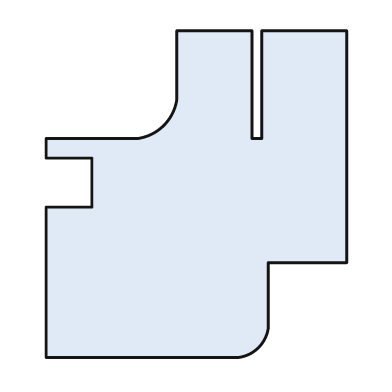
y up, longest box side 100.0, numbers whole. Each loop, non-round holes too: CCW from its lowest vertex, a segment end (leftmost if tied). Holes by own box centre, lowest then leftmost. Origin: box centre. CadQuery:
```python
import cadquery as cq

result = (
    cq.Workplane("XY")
    .moveTo(-46.0, -50.0)
    .lineTo(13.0, -50.0)
    .threePointArc((19.0, -47.0), (22.0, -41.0))
    .lineTo(22.0, -21.0)
    .lineTo(46.0, -21.0)
    .lineTo(46.0, 50.0)
    .lineTo(20.0, 50.0)
    .lineTo(20.0, 17.0)
    .lineTo(17.0, 17.0)
    .lineTo(17.0, 50.0)
    .lineTo(-6.0, 50.0)
    .lineTo(-6.0, 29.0)
    .threePointArc((-10.0, 21.0), (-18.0, 17.0))
    .lineTo(-46.0, 17.0)
    .lineTo(-46.0, 11.0)
    .lineTo(-32.0, 11.0)
    .lineTo(-32.0, -4.0)
    .lineTo(-46.0, -4.0)
    .close()
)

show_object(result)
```